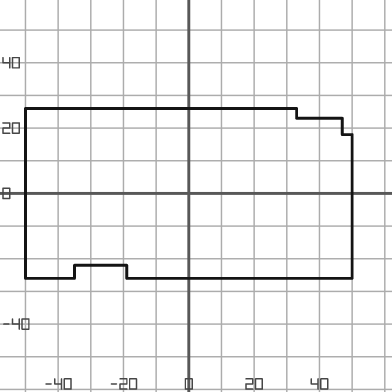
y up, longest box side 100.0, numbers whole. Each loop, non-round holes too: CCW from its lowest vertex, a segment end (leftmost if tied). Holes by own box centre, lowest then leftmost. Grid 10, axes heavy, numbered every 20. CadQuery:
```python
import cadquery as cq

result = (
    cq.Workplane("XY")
    .moveTo(-50.0, -26.0)
    .lineTo(-35.0, -26.0)
    .lineTo(-35.0, -22.0)
    .lineTo(-19.0, -22.0)
    .lineTo(-19.0, -26.0)
    .lineTo(50.0, -26.0)
    .lineTo(50.0, 18.0)
    .lineTo(47.0, 18.0)
    .lineTo(47.0, 23.0)
    .lineTo(33.0, 23.0)
    .lineTo(33.0, 26.0)
    .lineTo(-50.0, 26.0)
    .close()
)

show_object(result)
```